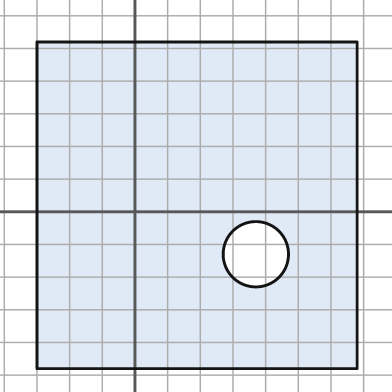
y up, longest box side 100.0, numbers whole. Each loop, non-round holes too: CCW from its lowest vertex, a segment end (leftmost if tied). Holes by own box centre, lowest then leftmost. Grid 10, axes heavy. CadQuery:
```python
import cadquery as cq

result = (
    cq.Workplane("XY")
    .moveTo(-30.0, -48.0)
    .lineTo(68.0, -48.0)
    .lineTo(68.0, 52.0)
    .lineTo(-30.0, 52.0)
    .close()
    .moveTo(37.0, -13.0)
    .circle(10.0)
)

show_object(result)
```